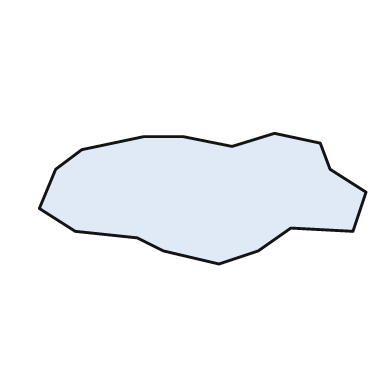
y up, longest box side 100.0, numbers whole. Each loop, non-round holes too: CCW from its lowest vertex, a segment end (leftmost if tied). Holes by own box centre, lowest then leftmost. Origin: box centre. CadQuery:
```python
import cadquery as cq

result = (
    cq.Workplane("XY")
    .moveTo(5.0, -20.0)
    .lineTo(17.0, -16.0)
    .lineTo(27.0, -9.0)
    .lineTo(46.0, -10.0)
    .lineTo(50.0, 2.0)
    .lineTo(39.0, 9.0)
    .lineTo(36.0, 17.0)
    .lineTo(22.0, 20.0)
    .lineTo(9.0, 16.0)
    .lineTo(-6.0, 19.0)
    .lineTo(-18.0, 19.0)
    .lineTo(-37.0, 15.0)
    .lineTo(-45.0, 9.0)
    .lineTo(-50.0, -3.0)
    .lineTo(-39.0, -10.0)
    .lineTo(-20.0, -12.0)
    .lineTo(-12.0, -16.0)
    .close()
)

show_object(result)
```